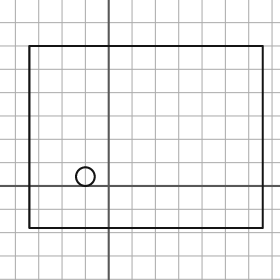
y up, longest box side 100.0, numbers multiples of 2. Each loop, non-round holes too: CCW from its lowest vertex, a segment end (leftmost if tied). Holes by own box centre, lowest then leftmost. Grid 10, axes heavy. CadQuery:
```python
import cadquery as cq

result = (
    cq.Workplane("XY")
    .moveTo(-34.0, -18.0)
    .lineTo(66.0, -18.0)
    .lineTo(66.0, 60.0)
    .lineTo(-34.0, 60.0)
    .close()
    .moveTo(-10.0, 4.0)
    .circle(4.0)
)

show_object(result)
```